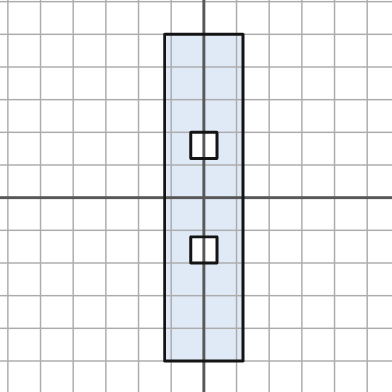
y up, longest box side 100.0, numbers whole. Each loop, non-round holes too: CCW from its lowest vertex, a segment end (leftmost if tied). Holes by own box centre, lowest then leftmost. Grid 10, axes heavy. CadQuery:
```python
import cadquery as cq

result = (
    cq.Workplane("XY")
    .moveTo(-12.0, -50.0)
    .lineTo(12.0, -50.0)
    .lineTo(12.0, 50.0)
    .lineTo(-12.0, 50.0)
    .close()
    .moveTo(-4.0, -20.0)
    .lineTo(4.0, -20.0)
    .lineTo(4.0, -12.0)
    .lineTo(-4.0, -12.0)
    .close()
    .moveTo(-4.0, 12.0)
    .lineTo(4.0, 12.0)
    .lineTo(4.0, 20.0)
    .lineTo(-4.0, 20.0)
    .close()
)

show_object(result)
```